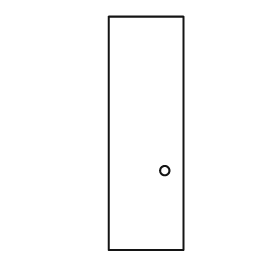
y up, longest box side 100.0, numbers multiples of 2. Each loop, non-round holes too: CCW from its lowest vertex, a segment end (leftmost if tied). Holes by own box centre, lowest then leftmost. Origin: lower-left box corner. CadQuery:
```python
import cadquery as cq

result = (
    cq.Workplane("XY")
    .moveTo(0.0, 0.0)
    .lineTo(32.0, 0.0)
    .lineTo(32.0, 100.0)
    .lineTo(0.0, 100.0)
    .close()
    .moveTo(24.0, 34.0)
    .circle(2.0)
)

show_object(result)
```